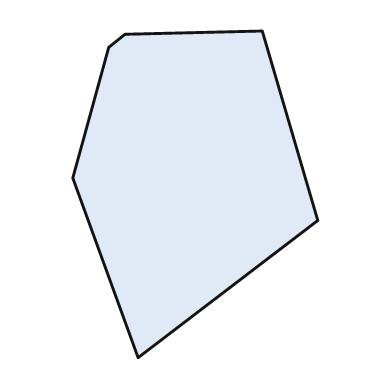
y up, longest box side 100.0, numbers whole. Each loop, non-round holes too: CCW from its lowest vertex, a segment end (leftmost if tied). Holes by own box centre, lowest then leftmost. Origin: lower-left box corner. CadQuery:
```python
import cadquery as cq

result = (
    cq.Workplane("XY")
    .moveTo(20.0, 0.0)
    .lineTo(75.0, 42.0)
    .lineTo(58.0, 100.0)
    .lineTo(16.0, 99.0)
    .lineTo(11.0, 95.0)
    .lineTo(0.0, 55.0)
    .close()
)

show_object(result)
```